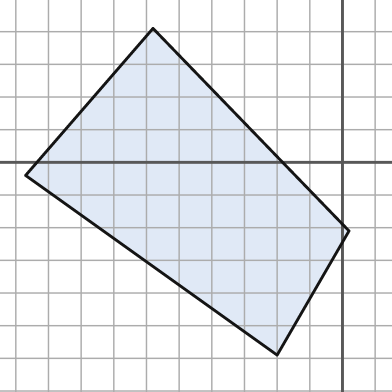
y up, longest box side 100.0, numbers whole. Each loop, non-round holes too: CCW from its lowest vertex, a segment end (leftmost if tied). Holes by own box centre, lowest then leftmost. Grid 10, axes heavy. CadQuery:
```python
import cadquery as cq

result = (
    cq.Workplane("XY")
    .moveTo(-20.0, -59.0)
    .lineTo(2.0, -21.0)
    .lineTo(-58.0, 41.0)
    .lineTo(-97.0, -4.0)
    .close()
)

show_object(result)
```